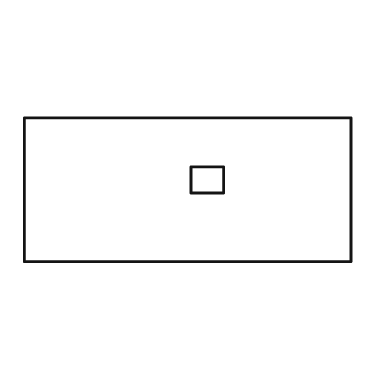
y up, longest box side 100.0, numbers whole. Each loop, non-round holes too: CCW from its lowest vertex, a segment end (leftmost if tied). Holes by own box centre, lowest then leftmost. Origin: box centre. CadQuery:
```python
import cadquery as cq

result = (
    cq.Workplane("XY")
    .moveTo(-50.0, -22.0)
    .lineTo(50.0, -22.0)
    .lineTo(50.0, 22.0)
    .lineTo(-50.0, 22.0)
    .close()
    .moveTo(1.0, -1.0)
    .lineTo(11.0, -1.0)
    .lineTo(11.0, 7.0)
    .lineTo(1.0, 7.0)
    .close()
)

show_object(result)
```